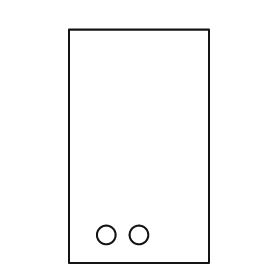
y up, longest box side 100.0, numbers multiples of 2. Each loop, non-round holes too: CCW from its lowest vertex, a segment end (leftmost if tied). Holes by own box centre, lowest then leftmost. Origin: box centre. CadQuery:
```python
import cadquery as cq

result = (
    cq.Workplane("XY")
    .moveTo(-30.0, -50.0)
    .lineTo(30.0, -50.0)
    .lineTo(30.0, 50.0)
    .lineTo(-30.0, 50.0)
    .close()
    .moveTo(-14.0, -38.0)
    .circle(4.0)
    .moveTo(0.0, -38.0)
    .circle(4.0)
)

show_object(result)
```